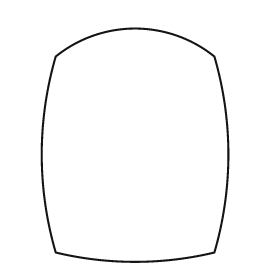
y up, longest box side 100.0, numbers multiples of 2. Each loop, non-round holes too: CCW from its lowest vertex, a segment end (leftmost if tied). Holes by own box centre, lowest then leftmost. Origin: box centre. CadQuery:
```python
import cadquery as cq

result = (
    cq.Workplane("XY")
    .moveTo(-34.0, -46.0)
    .threePointArc((0.0, -50.0), (34.0, -46.0))
    .threePointArc((40.0, -4.0), (34.0, 38.0))
    .threePointArc((0.0, 50.0), (-34.0, 38.0))
    .threePointArc((-40.0, -4.0), (-34.0, -46.0))
    .close()
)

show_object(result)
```